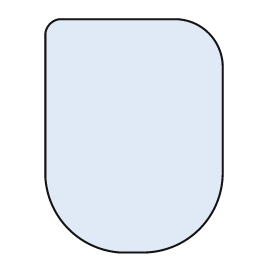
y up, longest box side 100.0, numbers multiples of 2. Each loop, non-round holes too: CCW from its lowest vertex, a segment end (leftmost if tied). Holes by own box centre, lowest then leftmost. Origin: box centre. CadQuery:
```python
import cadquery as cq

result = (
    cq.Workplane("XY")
    .moveTo(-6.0, -50.0)
    .lineTo(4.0, -50.0)
    .threePointArc((28.0, -40.0), (38.0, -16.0))
    .lineTo(38.0, 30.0)
    .threePointArc((32.0, 44.0), (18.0, 50.0))
    .lineTo(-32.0, 50.0)
    .threePointArc((-36.0, 48.0), (-38.0, 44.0))
    .lineTo(-38.0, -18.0)
    .threePointArc((-28.0, -40.0), (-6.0, -50.0))
    .close()
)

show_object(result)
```